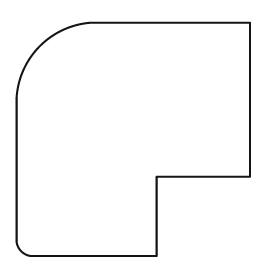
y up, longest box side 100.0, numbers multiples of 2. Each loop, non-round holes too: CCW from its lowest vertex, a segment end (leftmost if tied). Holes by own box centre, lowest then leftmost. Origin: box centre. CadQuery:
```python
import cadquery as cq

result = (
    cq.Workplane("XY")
    .moveTo(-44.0, -50.0)
    .lineTo(10.0, -50.0)
    .lineTo(10.0, -16.0)
    .lineTo(50.0, -16.0)
    .lineTo(50.0, 50.0)
    .lineTo(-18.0, 50.0)
    .threePointArc((-40.0, 40.0), (-50.0, 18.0))
    .lineTo(-50.0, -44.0)
    .threePointArc((-48.0, -48.0), (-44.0, -50.0))
    .close()
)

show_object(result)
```